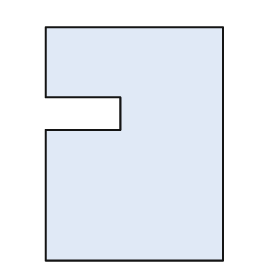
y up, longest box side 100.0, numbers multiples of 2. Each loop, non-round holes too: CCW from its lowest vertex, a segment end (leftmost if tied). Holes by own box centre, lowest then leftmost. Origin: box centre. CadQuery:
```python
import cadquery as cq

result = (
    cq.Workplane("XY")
    .moveTo(-38.0, -50.0)
    .lineTo(38.0, -50.0)
    .lineTo(38.0, 50.0)
    .lineTo(-38.0, 50.0)
    .lineTo(-38.0, 20.0)
    .lineTo(-6.0, 20.0)
    .lineTo(-6.0, 6.0)
    .lineTo(-38.0, 6.0)
    .close()
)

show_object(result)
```